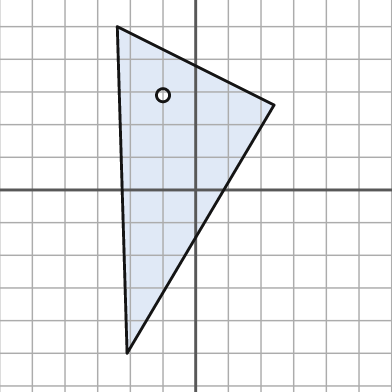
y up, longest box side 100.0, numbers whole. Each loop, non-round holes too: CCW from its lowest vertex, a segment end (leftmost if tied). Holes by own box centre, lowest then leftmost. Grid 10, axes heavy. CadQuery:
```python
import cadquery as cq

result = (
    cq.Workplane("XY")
    .moveTo(-21.0, -50.0)
    .lineTo(24.0, 26.0)
    .lineTo(-24.0, 50.0)
    .close()
    .moveTo(-10.0, 29.0)
    .circle(2.0)
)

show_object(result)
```